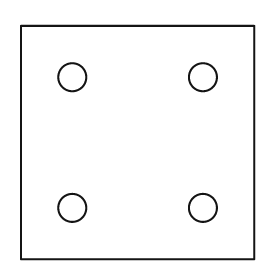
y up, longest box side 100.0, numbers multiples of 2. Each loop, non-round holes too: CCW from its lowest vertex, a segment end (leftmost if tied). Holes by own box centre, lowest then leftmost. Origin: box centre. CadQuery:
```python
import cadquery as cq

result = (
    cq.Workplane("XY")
    .moveTo(-50.0, -50.0)
    .lineTo(50.0, -50.0)
    .lineTo(50.0, 50.0)
    .lineTo(-50.0, 50.0)
    .close()
    .moveTo(-28.0, -28.0)
    .circle(6.0)
    .moveTo(28.0, -28.0)
    .circle(6.0)
    .moveTo(-28.0, 28.0)
    .circle(6.0)
    .moveTo(28.0, 28.0)
    .circle(6.0)
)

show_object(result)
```